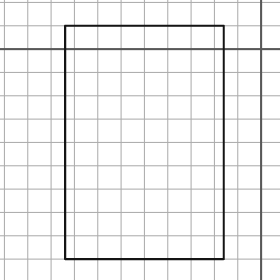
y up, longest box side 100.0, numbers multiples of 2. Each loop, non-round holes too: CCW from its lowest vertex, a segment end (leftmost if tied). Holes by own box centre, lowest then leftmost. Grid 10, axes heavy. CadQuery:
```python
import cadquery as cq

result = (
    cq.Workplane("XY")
    .moveTo(-84.0, -90.0)
    .lineTo(-16.0, -90.0)
    .lineTo(-16.0, 10.0)
    .lineTo(-84.0, 10.0)
    .close()
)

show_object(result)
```